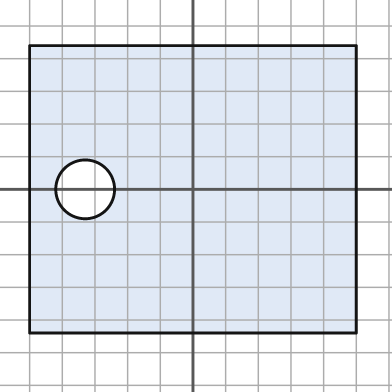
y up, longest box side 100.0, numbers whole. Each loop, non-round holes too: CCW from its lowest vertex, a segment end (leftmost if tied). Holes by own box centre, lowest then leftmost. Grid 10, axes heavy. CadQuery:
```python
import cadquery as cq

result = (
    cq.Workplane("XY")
    .moveTo(-50.0, -44.0)
    .lineTo(50.0, -44.0)
    .lineTo(50.0, 44.0)
    .lineTo(-50.0, 44.0)
    .close()
    .moveTo(-33.0, 0.0)
    .circle(9.0)
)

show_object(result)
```